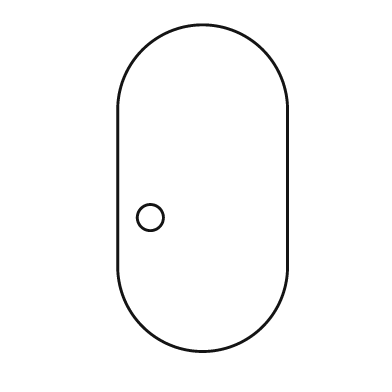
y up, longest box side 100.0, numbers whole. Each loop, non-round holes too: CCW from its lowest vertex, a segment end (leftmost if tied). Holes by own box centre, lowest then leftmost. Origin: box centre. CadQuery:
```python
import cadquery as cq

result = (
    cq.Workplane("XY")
    .moveTo(-26.0, -24.0)
    .threePointArc((0.0, -50.0), (26.0, -24.0))
    .lineTo(26.0, 24.0)
    .threePointArc((0.0, 50.0), (-26.0, 24.0))
    .close()
    .moveTo(-16.0, -9.0)
    .circle(4.0)
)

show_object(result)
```